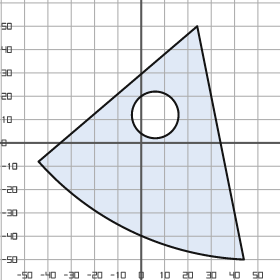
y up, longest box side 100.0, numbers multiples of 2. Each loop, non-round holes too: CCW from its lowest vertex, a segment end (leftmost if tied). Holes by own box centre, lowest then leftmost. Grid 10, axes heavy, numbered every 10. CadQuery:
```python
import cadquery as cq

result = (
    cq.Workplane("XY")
    .moveTo(44.0, -50.0)
    .lineTo(24.0, 50.0)
    .lineTo(-44.0, -8.0)
    .threePointArc((-4.0, -38.0), (44.0, -50.0))
    .close()
    .moveTo(6.0, 12.0)
    .circle(10.0)
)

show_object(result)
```